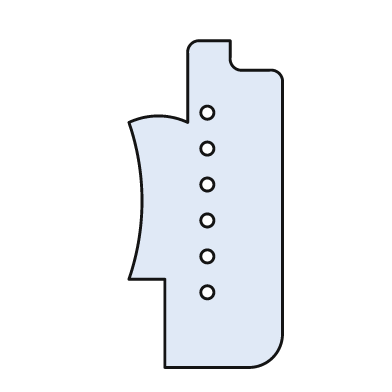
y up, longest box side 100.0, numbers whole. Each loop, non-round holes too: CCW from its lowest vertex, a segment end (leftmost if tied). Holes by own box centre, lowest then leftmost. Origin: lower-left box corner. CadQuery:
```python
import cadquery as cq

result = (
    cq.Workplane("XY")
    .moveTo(11.0, 0.0)
    .lineTo(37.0, 0.0)
    .threePointArc((44.0, 3.0), (47.0, 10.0))
    .lineTo(47.0, 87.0)
    .threePointArc((46.0, 90.0), (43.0, 91.0))
    .lineTo(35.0, 91.0)
    .threePointArc((32.0, 92.0), (31.0, 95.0))
    .lineTo(31.0, 100.0)
    .lineTo(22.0, 100.0)
    .threePointArc((19.0, 99.0), (18.0, 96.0))
    .lineTo(18.0, 75.0)
    .threePointArc((9.0, 77.0), (0.0, 75.0))
    .threePointArc((4.0, 51.0), (0.0, 27.0))
    .lineTo(11.0, 27.0)
    .close()
    .moveTo(24.0, 23.0)
    .circle(2.0)
    .moveTo(24.0, 34.0)
    .circle(2.0)
    .moveTo(24.0, 45.0)
    .circle(2.0)
    .moveTo(24.0, 56.0)
    .circle(2.0)
    .moveTo(24.0, 67.0)
    .circle(2.0)
    .moveTo(24.0, 78.0)
    .circle(2.0)
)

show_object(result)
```